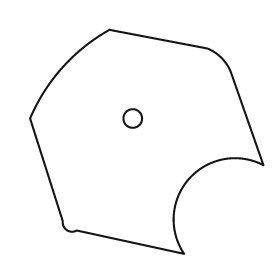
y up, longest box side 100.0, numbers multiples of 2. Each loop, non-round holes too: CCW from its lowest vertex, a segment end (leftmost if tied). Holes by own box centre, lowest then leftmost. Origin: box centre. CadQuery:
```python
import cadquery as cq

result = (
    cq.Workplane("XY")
    .moveTo(16.0, -48.0)
    .threePointArc((18.0, -16.0), (50.0, -10.0))
    .lineTo(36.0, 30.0)
    .threePointArc((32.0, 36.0), (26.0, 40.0))
    .lineTo(-16.0, 48.0)
    .threePointArc((-36.0, 32.0), (-50.0, 10.0))
    .lineTo(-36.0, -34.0)
    .threePointArc((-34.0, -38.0), (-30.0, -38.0))
    .close()
    .moveTo(-6.0, 10.0)
    .circle(4.0)
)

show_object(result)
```